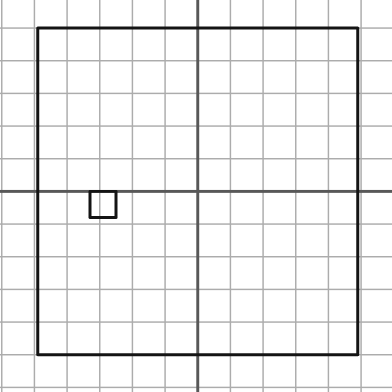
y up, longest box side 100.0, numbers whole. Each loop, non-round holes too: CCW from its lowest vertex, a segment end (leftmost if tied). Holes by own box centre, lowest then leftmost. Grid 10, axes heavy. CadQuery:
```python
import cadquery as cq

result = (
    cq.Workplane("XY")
    .moveTo(-49.0, -50.0)
    .lineTo(49.0, -50.0)
    .lineTo(49.0, 50.0)
    .lineTo(-49.0, 50.0)
    .close()
    .moveTo(-33.0, -8.0)
    .lineTo(-25.0, -8.0)
    .lineTo(-25.0, 0.0)
    .lineTo(-33.0, 0.0)
    .close()
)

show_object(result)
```